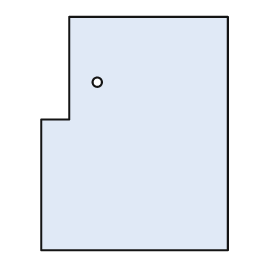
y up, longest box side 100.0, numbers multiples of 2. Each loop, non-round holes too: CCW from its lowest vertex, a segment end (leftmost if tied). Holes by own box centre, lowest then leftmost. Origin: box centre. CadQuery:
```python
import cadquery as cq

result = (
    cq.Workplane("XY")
    .moveTo(-40.0, -50.0)
    .lineTo(40.0, -50.0)
    .lineTo(40.0, 50.0)
    .lineTo(-28.0, 50.0)
    .lineTo(-28.0, 6.0)
    .lineTo(-40.0, 6.0)
    .close()
    .moveTo(-16.0, 22.0)
    .circle(2.0)
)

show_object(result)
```